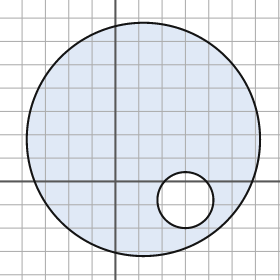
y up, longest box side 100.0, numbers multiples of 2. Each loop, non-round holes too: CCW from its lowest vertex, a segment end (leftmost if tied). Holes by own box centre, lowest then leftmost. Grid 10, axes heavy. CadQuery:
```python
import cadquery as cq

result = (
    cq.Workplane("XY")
    .moveTo(12.0, 18.0)
    .circle(50.0)
    .moveTo(30.0, -8.0)
    .circle(12.0)
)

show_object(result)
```